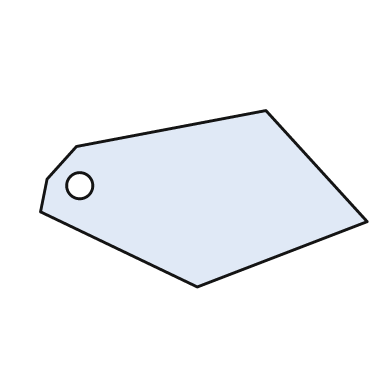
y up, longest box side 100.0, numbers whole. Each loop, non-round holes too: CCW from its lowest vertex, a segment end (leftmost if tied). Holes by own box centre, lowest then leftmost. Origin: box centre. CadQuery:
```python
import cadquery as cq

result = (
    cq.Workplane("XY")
    .moveTo(-2.0, -27.0)
    .lineTo(50.0, -7.0)
    .lineTo(19.0, 27.0)
    .lineTo(-39.0, 16.0)
    .lineTo(-48.0, 6.0)
    .lineTo(-50.0, -4.0)
    .close()
    .moveTo(-38.0, 4.0)
    .circle(4.0)
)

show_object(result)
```